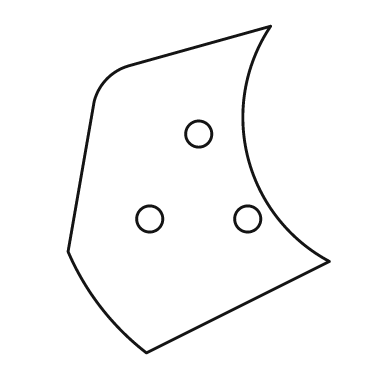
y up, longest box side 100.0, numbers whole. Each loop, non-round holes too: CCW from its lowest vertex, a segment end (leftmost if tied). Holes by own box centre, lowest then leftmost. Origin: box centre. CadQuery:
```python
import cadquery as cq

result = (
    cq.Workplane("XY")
    .moveTo(-16.0, -50.0)
    .lineTo(40.0, -22.0)
    .threePointArc((15.0, 10.0), (22.0, 50.0))
    .lineTo(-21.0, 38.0)
    .threePointArc((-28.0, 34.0), (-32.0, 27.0))
    .lineTo(-40.0, -19.0)
    .threePointArc((-30.0, -36.0), (-16.0, -50.0))
    .close()
    .moveTo(-15.0, -9.0)
    .circle(4.0)
    .moveTo(15.0, -9.0)
    .circle(4.0)
    .moveTo(0.0, 17.0)
    .circle(4.0)
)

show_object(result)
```